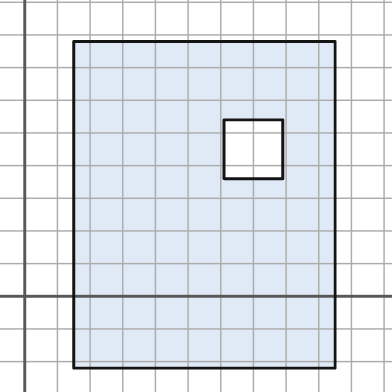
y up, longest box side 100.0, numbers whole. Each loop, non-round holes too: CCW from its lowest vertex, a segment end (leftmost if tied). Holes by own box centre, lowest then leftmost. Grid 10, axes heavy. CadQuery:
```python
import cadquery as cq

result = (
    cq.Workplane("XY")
    .moveTo(15.0, -22.0)
    .lineTo(95.0, -22.0)
    .lineTo(95.0, 78.0)
    .lineTo(15.0, 78.0)
    .close()
    .moveTo(61.0, 36.0)
    .lineTo(79.0, 36.0)
    .lineTo(79.0, 54.0)
    .lineTo(61.0, 54.0)
    .close()
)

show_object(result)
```